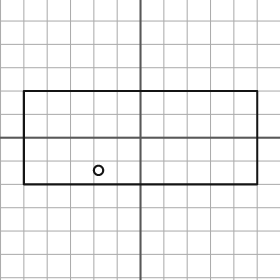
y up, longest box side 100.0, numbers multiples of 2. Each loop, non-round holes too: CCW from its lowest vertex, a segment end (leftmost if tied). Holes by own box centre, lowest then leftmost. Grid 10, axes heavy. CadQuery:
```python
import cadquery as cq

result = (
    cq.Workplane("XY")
    .moveTo(-50.0, -20.0)
    .lineTo(50.0, -20.0)
    .lineTo(50.0, 20.0)
    .lineTo(-50.0, 20.0)
    .close()
    .moveTo(-18.0, -14.0)
    .circle(2.0)
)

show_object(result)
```